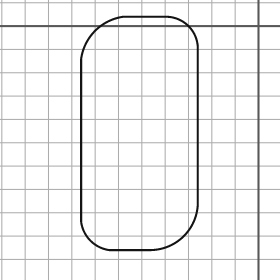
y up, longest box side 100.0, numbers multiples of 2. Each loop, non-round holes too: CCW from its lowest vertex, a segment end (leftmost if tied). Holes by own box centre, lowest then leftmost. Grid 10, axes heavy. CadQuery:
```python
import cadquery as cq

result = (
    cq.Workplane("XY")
    .moveTo(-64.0, -96.0)
    .lineTo(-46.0, -96.0)
    .threePointArc((-32.0, -90.0), (-26.0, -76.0))
    .lineTo(-26.0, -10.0)
    .threePointArc((-30.0, 0.0), (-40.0, 4.0))
    .lineTo(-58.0, 4.0)
    .threePointArc((-70.0, -2.0), (-76.0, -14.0))
    .lineTo(-76.0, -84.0)
    .threePointArc((-72.0, -92.0), (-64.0, -96.0))
    .close()
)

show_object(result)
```